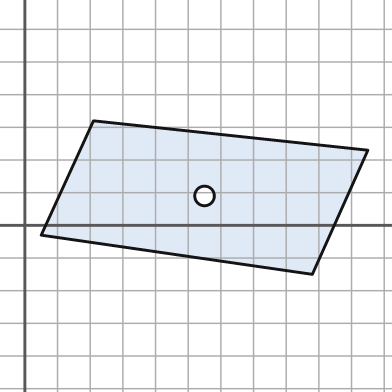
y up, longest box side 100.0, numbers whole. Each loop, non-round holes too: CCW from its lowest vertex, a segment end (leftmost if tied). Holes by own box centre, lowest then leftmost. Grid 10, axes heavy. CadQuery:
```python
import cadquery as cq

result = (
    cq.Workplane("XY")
    .moveTo(88.0, -15.0)
    .lineTo(105.0, 23.0)
    .lineTo(21.0, 32.0)
    .lineTo(5.0, -3.0)
    .close()
    .moveTo(55.0, 9.0)
    .circle(3.0)
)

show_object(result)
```